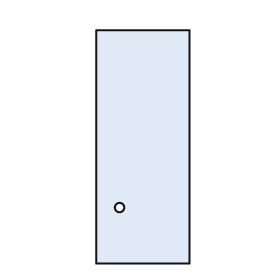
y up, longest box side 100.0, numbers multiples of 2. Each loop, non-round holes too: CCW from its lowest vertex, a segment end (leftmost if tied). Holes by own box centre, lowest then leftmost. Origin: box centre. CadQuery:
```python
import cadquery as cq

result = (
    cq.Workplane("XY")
    .moveTo(-20.0, -50.0)
    .lineTo(20.0, -50.0)
    .lineTo(20.0, 50.0)
    .lineTo(-20.0, 50.0)
    .close()
    .moveTo(-10.0, -26.0)
    .circle(2.0)
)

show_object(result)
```